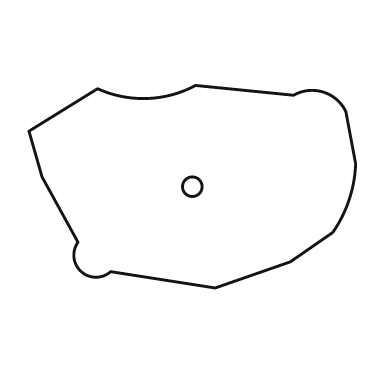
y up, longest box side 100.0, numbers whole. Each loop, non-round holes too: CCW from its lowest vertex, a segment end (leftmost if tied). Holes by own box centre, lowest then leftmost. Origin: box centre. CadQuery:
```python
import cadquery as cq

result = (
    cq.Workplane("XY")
    .moveTo(7.0, -31.0)
    .lineTo(30.0, -23.0)
    .lineTo(43.0, -14.0)
    .threePointArc((48.0, -4.0), (50.0, 7.0))
    .lineTo(47.0, 23.0)
    .threePointArc((40.0, 29.0), (31.0, 28.0))
    .lineTo(1.0, 31.0)
    .threePointArc((-14.0, 27.0), (-29.0, 30.0))
    .lineTo(-50.0, 17.0)
    .lineTo(-46.0, 3.0)
    .lineTo(-35.0, -17.0)
    .threePointArc((-34.0, -26.0), (-25.0, -26.0))
    .close()
    .moveTo(0.0, 0.0)
    .circle(3.0)
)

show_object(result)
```